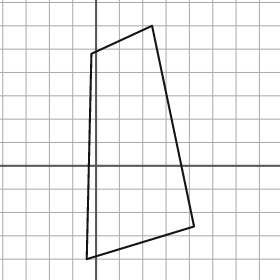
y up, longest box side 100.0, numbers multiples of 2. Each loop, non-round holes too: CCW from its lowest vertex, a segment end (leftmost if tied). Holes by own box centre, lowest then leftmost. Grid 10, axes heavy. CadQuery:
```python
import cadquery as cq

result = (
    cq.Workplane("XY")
    .moveTo(-4.0, -40.0)
    .lineTo(42.0, -26.0)
    .lineTo(24.0, 60.0)
    .lineTo(-2.0, 48.0)
    .close()
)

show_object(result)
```